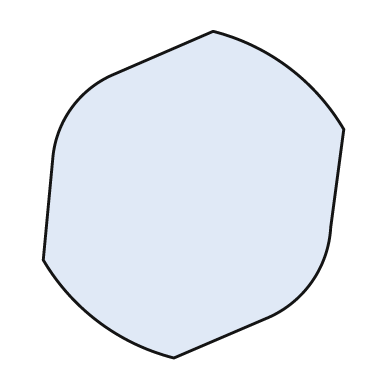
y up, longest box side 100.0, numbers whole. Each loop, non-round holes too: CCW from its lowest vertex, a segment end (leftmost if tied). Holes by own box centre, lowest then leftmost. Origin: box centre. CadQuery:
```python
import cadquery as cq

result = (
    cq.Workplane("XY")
    .moveTo(-6.0, -50.0)
    .lineTo(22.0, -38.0)
    .threePointArc((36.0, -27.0), (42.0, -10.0))
    .lineTo(46.0, 20.0)
    .threePointArc((29.0, 39.0), (6.0, 50.0))
    .lineTo(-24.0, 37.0)
    .threePointArc((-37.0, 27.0), (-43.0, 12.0))
    .lineTo(-46.0, -20.0)
    .threePointArc((-29.0, -39.0), (-6.0, -50.0))
    .close()
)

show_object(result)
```